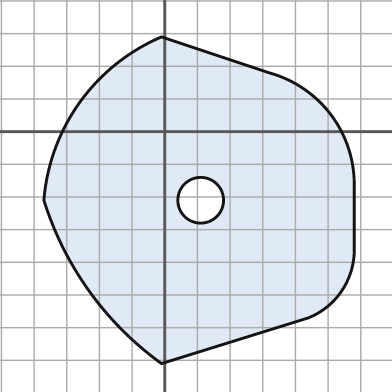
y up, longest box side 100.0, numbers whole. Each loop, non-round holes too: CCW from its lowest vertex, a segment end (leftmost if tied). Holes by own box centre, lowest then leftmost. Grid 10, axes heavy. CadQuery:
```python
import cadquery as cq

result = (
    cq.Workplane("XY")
    .moveTo(-1.0, -71.0)
    .lineTo(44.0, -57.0)
    .threePointArc((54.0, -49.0), (58.0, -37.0))
    .lineTo(58.0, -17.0)
    .threePointArc((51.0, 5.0), (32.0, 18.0))
    .lineTo(-1.0, 29.0)
    .threePointArc((-26.0, 9.0), (-37.0, -21.0))
    .threePointArc((-23.0, -49.0), (-1.0, -71.0))
    .close()
    .moveTo(11.0, -21.0)
    .circle(7.0)
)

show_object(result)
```